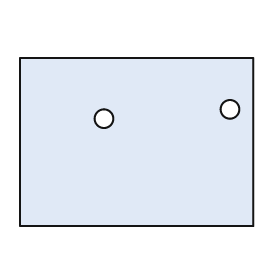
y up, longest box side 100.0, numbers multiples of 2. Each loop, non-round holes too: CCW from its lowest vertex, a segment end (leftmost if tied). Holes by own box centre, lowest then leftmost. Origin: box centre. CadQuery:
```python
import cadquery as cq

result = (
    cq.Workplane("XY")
    .moveTo(-50.0, -36.0)
    .lineTo(50.0, -36.0)
    .lineTo(50.0, 36.0)
    .lineTo(-50.0, 36.0)
    .close()
    .moveTo(-14.0, 10.0)
    .circle(4.0)
    .moveTo(40.0, 14.0)
    .circle(4.0)
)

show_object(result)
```